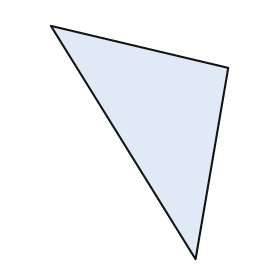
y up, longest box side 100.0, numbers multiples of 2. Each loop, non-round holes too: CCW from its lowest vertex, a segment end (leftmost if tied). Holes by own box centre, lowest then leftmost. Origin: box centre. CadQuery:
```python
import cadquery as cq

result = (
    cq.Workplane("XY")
    .moveTo(24.0, -50.0)
    .lineTo(38.0, 32.0)
    .lineTo(-38.0, 50.0)
    .close()
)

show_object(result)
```